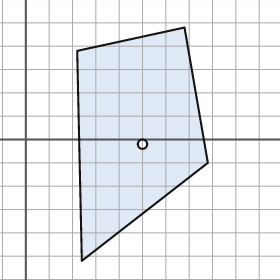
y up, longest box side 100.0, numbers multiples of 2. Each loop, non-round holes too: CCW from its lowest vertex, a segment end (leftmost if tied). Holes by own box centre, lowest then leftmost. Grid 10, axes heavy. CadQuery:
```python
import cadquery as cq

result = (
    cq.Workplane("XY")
    .moveTo(24.0, -52.0)
    .lineTo(78.0, -10.0)
    .lineTo(68.0, 48.0)
    .lineTo(22.0, 38.0)
    .close()
    .moveTo(50.0, -2.0)
    .circle(2.0)
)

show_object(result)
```